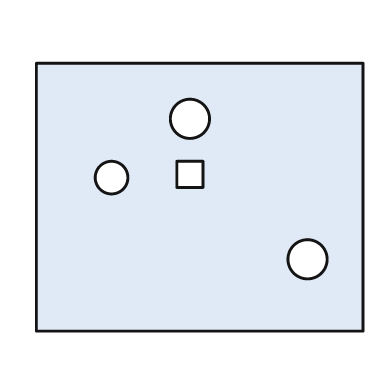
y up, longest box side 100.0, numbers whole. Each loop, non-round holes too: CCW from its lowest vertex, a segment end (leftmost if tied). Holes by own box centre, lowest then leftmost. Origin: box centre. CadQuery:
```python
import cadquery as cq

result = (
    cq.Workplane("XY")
    .moveTo(-50.0, -41.0)
    .lineTo(50.0, -41.0)
    .lineTo(50.0, 41.0)
    .lineTo(-50.0, 41.0)
    .close()
    .moveTo(33.0, -19.0)
    .circle(6.0)
    .moveTo(-27.0, 6.0)
    .circle(5.0)
    .moveTo(-7.0, 3.0)
    .lineTo(1.0, 3.0)
    .lineTo(1.0, 11.0)
    .lineTo(-7.0, 11.0)
    .close()
    .moveTo(-3.0, 24.0)
    .circle(6.0)
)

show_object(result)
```